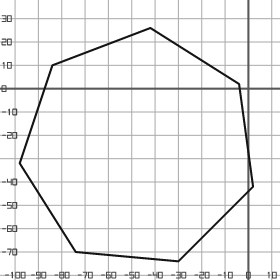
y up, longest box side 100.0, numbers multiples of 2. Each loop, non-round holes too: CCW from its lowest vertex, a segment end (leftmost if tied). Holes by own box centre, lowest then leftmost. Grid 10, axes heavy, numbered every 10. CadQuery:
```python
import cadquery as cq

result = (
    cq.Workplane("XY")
    .moveTo(-30.0, -74.0)
    .lineTo(2.0, -42.0)
    .lineTo(-4.0, 2.0)
    .lineTo(-42.0, 26.0)
    .lineTo(-84.0, 10.0)
    .lineTo(-98.0, -32.0)
    .lineTo(-74.0, -70.0)
    .close()
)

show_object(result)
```